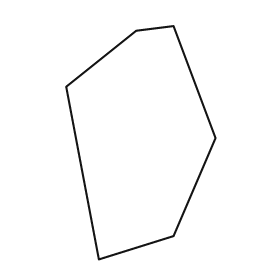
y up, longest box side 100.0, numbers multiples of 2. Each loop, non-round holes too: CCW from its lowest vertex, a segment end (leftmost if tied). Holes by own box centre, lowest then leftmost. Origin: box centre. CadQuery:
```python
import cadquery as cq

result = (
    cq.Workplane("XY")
    .moveTo(-18.0, -50.0)
    .lineTo(14.0, -40.0)
    .lineTo(32.0, 2.0)
    .lineTo(14.0, 50.0)
    .lineTo(-2.0, 48.0)
    .lineTo(-32.0, 24.0)
    .close()
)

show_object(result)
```